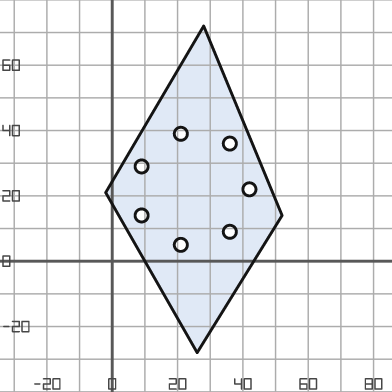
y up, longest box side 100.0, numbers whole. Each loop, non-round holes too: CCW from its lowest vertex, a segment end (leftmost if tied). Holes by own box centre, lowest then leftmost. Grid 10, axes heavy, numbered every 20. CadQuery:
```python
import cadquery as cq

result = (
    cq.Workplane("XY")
    .moveTo(26.0, -28.0)
    .lineTo(52.0, 14.0)
    .lineTo(28.0, 72.0)
    .lineTo(-2.0, 21.0)
    .close()
    .moveTo(21.0, 5.0)
    .circle(2.0)
    .moveTo(36.0, 9.0)
    .circle(2.0)
    .moveTo(9.0, 14.0)
    .circle(2.0)
    .moveTo(42.0, 22.0)
    .circle(2.0)
    .moveTo(9.0, 29.0)
    .circle(2.0)
    .moveTo(36.0, 36.0)
    .circle(2.0)
    .moveTo(21.0, 39.0)
    .circle(2.0)
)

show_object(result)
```